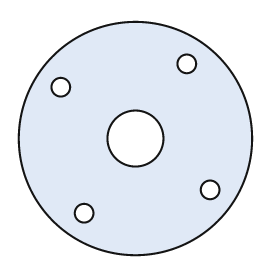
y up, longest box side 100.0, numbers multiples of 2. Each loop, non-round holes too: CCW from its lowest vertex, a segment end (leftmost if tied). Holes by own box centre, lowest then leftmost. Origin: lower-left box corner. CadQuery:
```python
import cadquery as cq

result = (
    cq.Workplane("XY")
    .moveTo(50.0, 50.0)
    .circle(50.0)
    .moveTo(28.0, 18.0)
    .circle(4.0)
    .moveTo(82.0, 28.0)
    .circle(4.0)
    .moveTo(50.0, 50.0)
    .circle(12.0)
    .moveTo(18.0, 72.0)
    .circle(4.0)
    .moveTo(72.0, 82.0)
    .circle(4.0)
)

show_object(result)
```